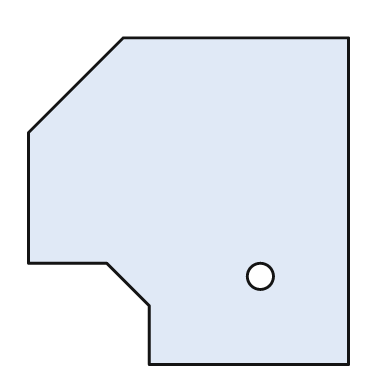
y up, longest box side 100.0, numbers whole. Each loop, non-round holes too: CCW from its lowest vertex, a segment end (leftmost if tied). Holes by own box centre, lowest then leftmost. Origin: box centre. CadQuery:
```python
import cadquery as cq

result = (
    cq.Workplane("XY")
    .moveTo(-12.0, -50.0)
    .lineTo(49.0, -50.0)
    .lineTo(49.0, 50.0)
    .lineTo(-20.0, 50.0)
    .lineTo(-49.0, 21.0)
    .lineTo(-49.0, -19.0)
    .lineTo(-25.0, -19.0)
    .lineTo(-12.0, -32.0)
    .close()
    .moveTo(22.0, -23.0)
    .circle(4.0)
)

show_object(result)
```